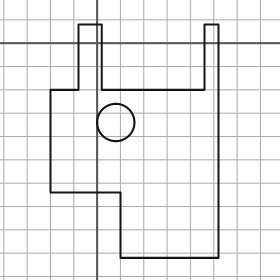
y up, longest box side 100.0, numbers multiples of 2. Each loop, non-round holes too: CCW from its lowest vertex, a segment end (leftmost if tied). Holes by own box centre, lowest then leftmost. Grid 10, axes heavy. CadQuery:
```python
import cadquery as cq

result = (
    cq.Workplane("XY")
    .moveTo(10.0, -92.0)
    .lineTo(52.0, -92.0)
    .lineTo(52.0, 8.0)
    .lineTo(46.0, 8.0)
    .lineTo(46.0, -20.0)
    .lineTo(2.0, -20.0)
    .lineTo(2.0, 8.0)
    .lineTo(-8.0, 8.0)
    .lineTo(-8.0, -20.0)
    .lineTo(-20.0, -20.0)
    .lineTo(-20.0, -64.0)
    .lineTo(10.0, -64.0)
    .close()
    .moveTo(8.0, -34.0)
    .circle(8.0)
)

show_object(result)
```